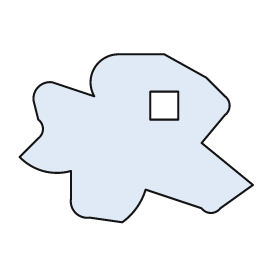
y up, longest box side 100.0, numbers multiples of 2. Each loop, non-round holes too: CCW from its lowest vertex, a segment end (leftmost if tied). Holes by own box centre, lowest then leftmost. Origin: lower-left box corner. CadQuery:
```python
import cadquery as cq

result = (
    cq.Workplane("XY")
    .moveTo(44.0, 0.0)
    .threePointArc((50.0, 6.0), (54.0, 14.0))
    .lineTo(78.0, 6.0)
    .threePointArc((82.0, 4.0), (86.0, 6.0))
    .lineTo(100.0, 16.0)
    .lineTo(78.0, 34.0)
    .lineTo(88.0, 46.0)
    .threePointArc((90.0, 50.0), (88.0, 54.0))
    .lineTo(80.0, 62.0)
    .lineTo(62.0, 72.0)
    .lineTo(42.0, 72.0)
    .threePointArc((32.0, 66.0), (32.0, 54.0))
    .lineTo(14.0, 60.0)
    .threePointArc((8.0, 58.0), (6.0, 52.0))
    .lineTo(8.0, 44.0)
    .threePointArc((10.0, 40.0), (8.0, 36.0))
    .lineTo(0.0, 28.0)
    .threePointArc((10.0, 22.0), (22.0, 22.0))
    .lineTo(22.0, 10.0)
    .threePointArc((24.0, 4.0), (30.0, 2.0))
    .close()
    .moveTo(56.0, 44.0)
    .lineTo(68.0, 44.0)
    .lineTo(68.0, 56.0)
    .lineTo(56.0, 56.0)
    .close()
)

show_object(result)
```